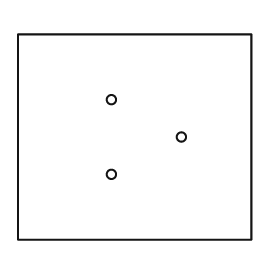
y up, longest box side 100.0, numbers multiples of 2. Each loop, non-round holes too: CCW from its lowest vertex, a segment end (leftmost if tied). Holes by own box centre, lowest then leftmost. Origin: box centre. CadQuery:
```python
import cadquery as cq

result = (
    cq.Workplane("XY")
    .moveTo(-50.0, -44.0)
    .lineTo(50.0, -44.0)
    .lineTo(50.0, 44.0)
    .lineTo(-50.0, 44.0)
    .close()
    .moveTo(-10.0, -16.0)
    .circle(2.0)
    .moveTo(20.0, 0.0)
    .circle(2.0)
    .moveTo(-10.0, 16.0)
    .circle(2.0)
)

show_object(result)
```